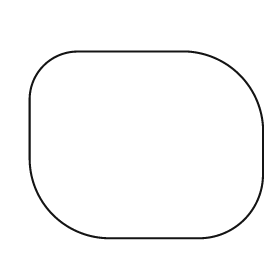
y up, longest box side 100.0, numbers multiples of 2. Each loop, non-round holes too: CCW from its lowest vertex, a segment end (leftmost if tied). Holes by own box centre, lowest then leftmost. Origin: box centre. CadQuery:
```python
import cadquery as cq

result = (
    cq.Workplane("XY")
    .moveTo(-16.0, -40.0)
    .lineTo(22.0, -40.0)
    .threePointArc((42.0, -32.0), (50.0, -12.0))
    .lineTo(50.0, 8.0)
    .threePointArc((40.0, 30.0), (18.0, 40.0))
    .lineTo(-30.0, 40.0)
    .threePointArc((-44.0, 34.0), (-50.0, 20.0))
    .lineTo(-50.0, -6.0)
    .threePointArc((-40.0, -30.0), (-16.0, -40.0))
    .close()
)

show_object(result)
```